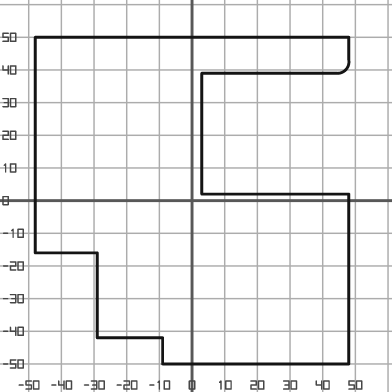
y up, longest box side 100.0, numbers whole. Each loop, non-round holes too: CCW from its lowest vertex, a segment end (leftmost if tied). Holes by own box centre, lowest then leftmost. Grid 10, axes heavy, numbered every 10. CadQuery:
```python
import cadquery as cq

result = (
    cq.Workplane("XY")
    .moveTo(-9.0, -50.0)
    .lineTo(48.0, -50.0)
    .lineTo(48.0, 2.0)
    .lineTo(3.0, 2.0)
    .lineTo(3.0, 39.0)
    .lineTo(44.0, 39.0)
    .threePointArc((47.0, 40.0), (48.0, 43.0))
    .lineTo(48.0, 50.0)
    .lineTo(-48.0, 50.0)
    .lineTo(-48.0, -16.0)
    .lineTo(-29.0, -16.0)
    .lineTo(-29.0, -42.0)
    .lineTo(-9.0, -42.0)
    .close()
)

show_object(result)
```